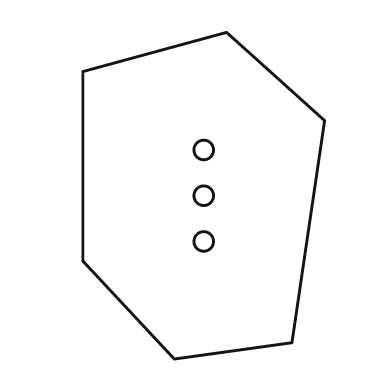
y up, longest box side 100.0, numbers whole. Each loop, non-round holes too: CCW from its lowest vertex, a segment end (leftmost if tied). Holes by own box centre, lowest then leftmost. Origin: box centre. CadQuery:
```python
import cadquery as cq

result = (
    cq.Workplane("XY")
    .moveTo(-9.0, -50.0)
    .lineTo(27.0, -45.0)
    .lineTo(37.0, 23.0)
    .lineTo(7.0, 50.0)
    .lineTo(-37.0, 38.0)
    .lineTo(-37.0, -20.0)
    .close()
    .moveTo(0.0, -14.0)
    .circle(3.0)
    .moveTo(0.0, 0.0)
    .circle(3.0)
    .moveTo(0.0, 14.0)
    .circle(3.0)
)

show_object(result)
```